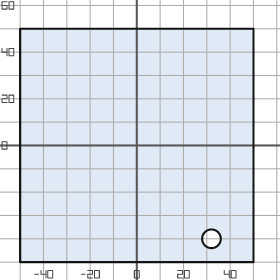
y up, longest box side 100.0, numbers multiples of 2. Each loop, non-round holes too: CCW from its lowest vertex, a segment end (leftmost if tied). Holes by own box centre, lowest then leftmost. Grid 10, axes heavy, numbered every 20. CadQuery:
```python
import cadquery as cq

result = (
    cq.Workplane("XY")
    .moveTo(-50.0, -50.0)
    .lineTo(50.0, -50.0)
    .lineTo(50.0, 50.0)
    .lineTo(-50.0, 50.0)
    .close()
    .moveTo(32.0, -40.0)
    .circle(4.0)
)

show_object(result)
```